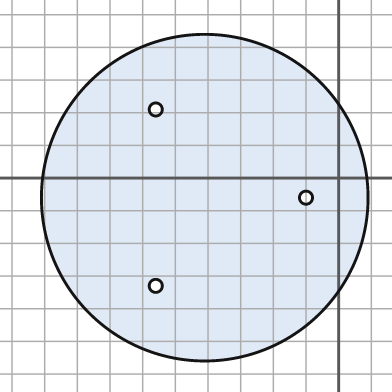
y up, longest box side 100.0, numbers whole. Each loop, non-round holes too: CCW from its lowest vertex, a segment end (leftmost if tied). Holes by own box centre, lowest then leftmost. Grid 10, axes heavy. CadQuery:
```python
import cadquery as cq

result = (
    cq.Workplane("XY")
    .moveTo(-41.0, -6.0)
    .circle(50.0)
    .moveTo(-56.0, -33.0)
    .circle(2.0)
    .moveTo(-10.0, -6.0)
    .circle(2.0)
    .moveTo(-56.0, 21.0)
    .circle(2.0)
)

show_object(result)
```